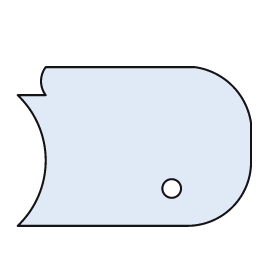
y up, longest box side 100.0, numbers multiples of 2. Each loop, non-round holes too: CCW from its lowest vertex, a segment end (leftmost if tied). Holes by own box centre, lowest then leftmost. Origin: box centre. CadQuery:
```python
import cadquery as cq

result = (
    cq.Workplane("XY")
    .moveTo(-50.0, -34.0)
    .lineTo(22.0, -34.0)
    .threePointArc((42.0, -26.0), (50.0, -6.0))
    .lineTo(50.0, 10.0)
    .threePointArc((42.0, 26.0), (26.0, 34.0))
    .lineTo(-38.0, 34.0)
    .threePointArc((-40.0, 28.0), (-38.0, 22.0))
    .lineTo(-50.0, 22.0)
    .threePointArc((-38.0, -6.0), (-50.0, -34.0))
    .close()
    .moveTo(16.0, -18.0)
    .circle(4.0)
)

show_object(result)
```